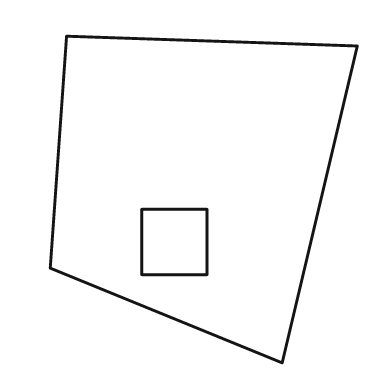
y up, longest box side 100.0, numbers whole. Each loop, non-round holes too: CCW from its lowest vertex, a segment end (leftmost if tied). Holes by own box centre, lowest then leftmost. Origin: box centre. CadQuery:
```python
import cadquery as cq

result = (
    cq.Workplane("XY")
    .moveTo(24.0, -50.0)
    .lineTo(47.0, 47.0)
    .lineTo(-42.0, 50.0)
    .lineTo(-47.0, -21.0)
    .close()
    .moveTo(-19.0, -23.0)
    .lineTo(1.0, -23.0)
    .lineTo(1.0, -3.0)
    .lineTo(-19.0, -3.0)
    .close()
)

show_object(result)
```